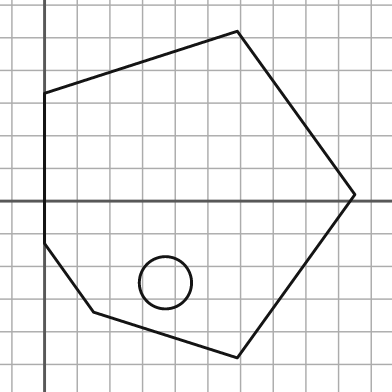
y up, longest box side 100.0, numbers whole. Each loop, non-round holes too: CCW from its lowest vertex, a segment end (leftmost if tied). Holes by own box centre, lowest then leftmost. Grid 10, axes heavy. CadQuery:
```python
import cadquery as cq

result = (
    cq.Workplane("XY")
    .moveTo(59.0, -48.0)
    .lineTo(95.0, 2.0)
    .lineTo(59.0, 52.0)
    .lineTo(0.0, 33.0)
    .lineTo(0.0, -13.0)
    .lineTo(15.0, -34.0)
    .close()
    .moveTo(37.0, -25.0)
    .circle(8.0)
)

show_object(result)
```